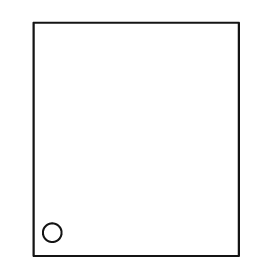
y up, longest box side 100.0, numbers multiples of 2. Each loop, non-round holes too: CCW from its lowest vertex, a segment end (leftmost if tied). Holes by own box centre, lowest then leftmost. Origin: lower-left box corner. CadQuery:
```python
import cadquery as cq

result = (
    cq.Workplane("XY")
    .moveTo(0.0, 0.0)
    .lineTo(88.0, 0.0)
    .lineTo(88.0, 100.0)
    .lineTo(0.0, 100.0)
    .close()
    .moveTo(8.0, 10.0)
    .circle(4.0)
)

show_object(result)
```